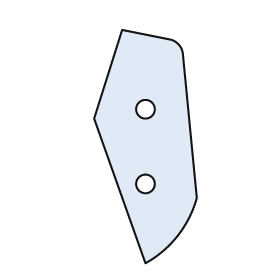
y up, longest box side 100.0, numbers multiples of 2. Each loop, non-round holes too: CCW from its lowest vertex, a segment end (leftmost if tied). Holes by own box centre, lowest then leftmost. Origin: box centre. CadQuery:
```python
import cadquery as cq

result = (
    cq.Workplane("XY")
    .moveTo(0.0, -50.0)
    .threePointArc((14.0, -38.0), (22.0, -22.0))
    .lineTo(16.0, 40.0)
    .threePointArc((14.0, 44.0), (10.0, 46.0))
    .lineTo(-10.0, 50.0)
    .lineTo(-22.0, 12.0)
    .close()
    .moveTo(0.0, -16.0)
    .circle(4.0)
    .moveTo(0.0, 16.0)
    .circle(4.0)
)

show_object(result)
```